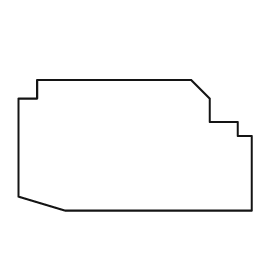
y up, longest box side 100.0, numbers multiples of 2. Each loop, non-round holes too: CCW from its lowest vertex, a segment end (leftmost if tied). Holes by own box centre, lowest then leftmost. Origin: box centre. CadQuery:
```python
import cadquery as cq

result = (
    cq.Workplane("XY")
    .moveTo(-30.0, -28.0)
    .lineTo(50.0, -28.0)
    .lineTo(50.0, 4.0)
    .lineTo(44.0, 4.0)
    .lineTo(44.0, 10.0)
    .lineTo(32.0, 10.0)
    .lineTo(32.0, 20.0)
    .lineTo(24.0, 28.0)
    .lineTo(-42.0, 28.0)
    .lineTo(-42.0, 20.0)
    .lineTo(-50.0, 20.0)
    .lineTo(-50.0, -22.0)
    .close()
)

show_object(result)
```